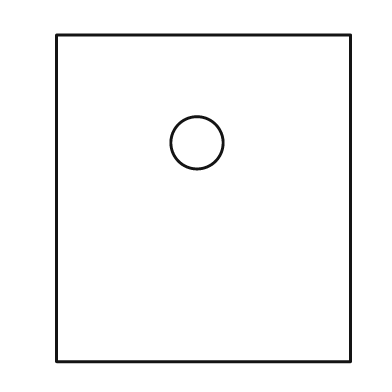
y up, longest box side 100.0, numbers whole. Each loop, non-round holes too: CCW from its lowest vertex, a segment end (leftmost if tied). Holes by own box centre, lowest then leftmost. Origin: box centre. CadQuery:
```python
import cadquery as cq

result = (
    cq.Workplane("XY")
    .moveTo(-45.0, -50.0)
    .lineTo(45.0, -50.0)
    .lineTo(45.0, 50.0)
    .lineTo(-45.0, 50.0)
    .close()
    .moveTo(-2.0, 17.0)
    .circle(8.0)
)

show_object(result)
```